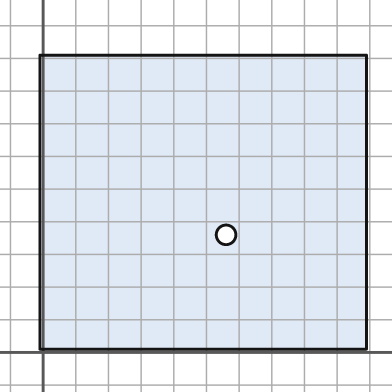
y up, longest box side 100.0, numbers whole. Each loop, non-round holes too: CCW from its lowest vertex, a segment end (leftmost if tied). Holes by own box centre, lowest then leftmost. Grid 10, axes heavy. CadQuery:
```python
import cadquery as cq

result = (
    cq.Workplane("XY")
    .moveTo(-1.0, 1.0)
    .lineTo(99.0, 1.0)
    .lineTo(99.0, 91.0)
    .lineTo(-1.0, 91.0)
    .close()
    .moveTo(56.0, 36.0)
    .circle(3.0)
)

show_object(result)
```